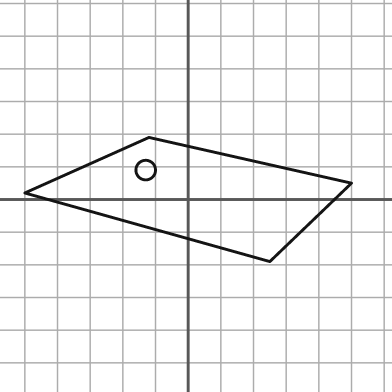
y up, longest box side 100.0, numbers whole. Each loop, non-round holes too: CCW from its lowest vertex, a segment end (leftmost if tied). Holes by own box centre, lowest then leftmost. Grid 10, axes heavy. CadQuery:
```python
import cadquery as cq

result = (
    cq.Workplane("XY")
    .moveTo(25.0, -19.0)
    .lineTo(50.0, 5.0)
    .lineTo(-12.0, 19.0)
    .lineTo(-50.0, 2.0)
    .close()
    .moveTo(-13.0, 9.0)
    .circle(3.0)
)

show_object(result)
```